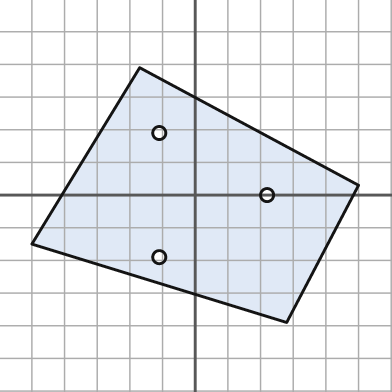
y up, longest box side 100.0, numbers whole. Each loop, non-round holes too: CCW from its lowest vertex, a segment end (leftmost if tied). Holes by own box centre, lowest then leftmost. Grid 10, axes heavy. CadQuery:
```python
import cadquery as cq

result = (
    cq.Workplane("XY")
    .moveTo(28.0, -39.0)
    .lineTo(50.0, 3.0)
    .lineTo(-17.0, 39.0)
    .lineTo(-50.0, -15.0)
    .close()
    .moveTo(-11.0, -19.0)
    .circle(2.0)
    .moveTo(22.0, 0.0)
    .circle(2.0)
    .moveTo(-11.0, 19.0)
    .circle(2.0)
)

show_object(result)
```